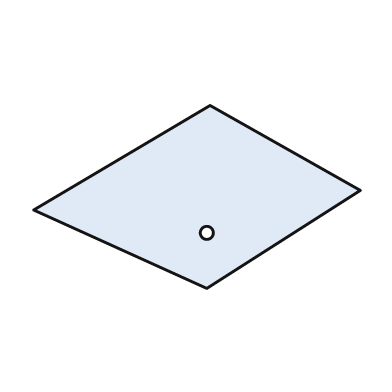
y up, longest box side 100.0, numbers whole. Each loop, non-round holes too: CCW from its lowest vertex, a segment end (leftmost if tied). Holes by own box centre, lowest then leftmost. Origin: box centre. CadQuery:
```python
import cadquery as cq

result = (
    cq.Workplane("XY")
    .moveTo(3.0, -28.0)
    .lineTo(50.0, 2.0)
    .lineTo(4.0, 28.0)
    .lineTo(-50.0, -4.0)
    .close()
    .moveTo(3.0, -11.0)
    .circle(2.0)
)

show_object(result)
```